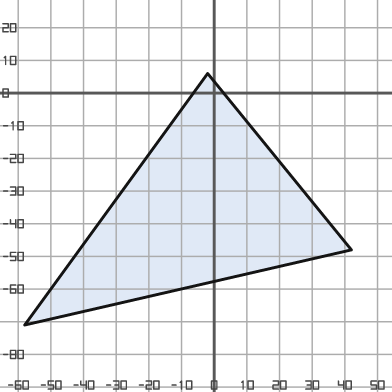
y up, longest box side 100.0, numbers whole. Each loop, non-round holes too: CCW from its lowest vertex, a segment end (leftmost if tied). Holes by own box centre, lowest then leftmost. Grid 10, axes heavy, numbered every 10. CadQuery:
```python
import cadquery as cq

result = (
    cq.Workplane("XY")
    .moveTo(-58.0, -71.0)
    .lineTo(42.0, -48.0)
    .lineTo(-2.0, 6.0)
    .close()
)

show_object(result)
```